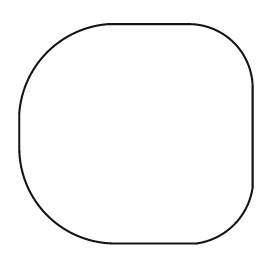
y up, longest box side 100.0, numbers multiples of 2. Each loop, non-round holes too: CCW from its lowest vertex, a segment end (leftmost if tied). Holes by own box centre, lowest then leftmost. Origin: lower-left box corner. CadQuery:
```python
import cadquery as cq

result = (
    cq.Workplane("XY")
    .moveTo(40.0, 0.0)
    .lineTo(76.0, 0.0)
    .threePointArc((92.0, 8.0), (100.0, 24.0))
    .lineTo(100.0, 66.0)
    .threePointArc((92.0, 86.0), (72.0, 94.0))
    .lineTo(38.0, 94.0)
    .threePointArc((12.0, 82.0), (0.0, 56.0))
    .lineTo(0.0, 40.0)
    .threePointArc((12.0, 12.0), (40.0, 0.0))
    .close()
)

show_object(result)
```